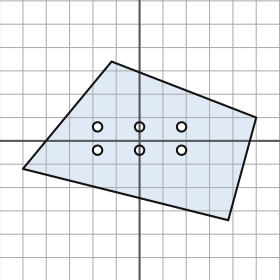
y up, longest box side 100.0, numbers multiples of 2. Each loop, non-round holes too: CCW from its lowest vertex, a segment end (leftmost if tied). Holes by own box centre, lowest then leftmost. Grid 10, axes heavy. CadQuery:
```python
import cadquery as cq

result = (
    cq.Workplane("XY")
    .moveTo(38.0, -34.0)
    .lineTo(50.0, 10.0)
    .lineTo(-12.0, 34.0)
    .lineTo(-50.0, -12.0)
    .close()
    .moveTo(-18.0, -4.0)
    .circle(2.0)
    .moveTo(0.0, -4.0)
    .circle(2.0)
    .moveTo(18.0, -4.0)
    .circle(2.0)
    .moveTo(-18.0, 6.0)
    .circle(2.0)
    .moveTo(0.0, 6.0)
    .circle(2.0)
    .moveTo(18.0, 6.0)
    .circle(2.0)
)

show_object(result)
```